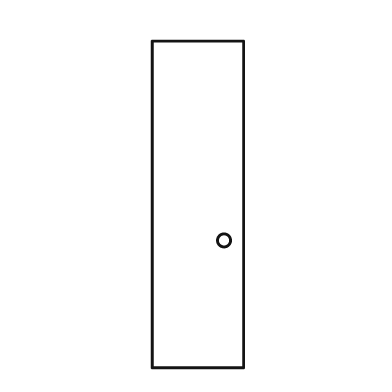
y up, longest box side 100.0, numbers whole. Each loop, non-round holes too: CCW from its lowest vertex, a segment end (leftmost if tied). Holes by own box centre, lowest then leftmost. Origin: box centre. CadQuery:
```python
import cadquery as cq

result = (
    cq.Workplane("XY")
    .moveTo(-14.0, -50.0)
    .lineTo(14.0, -50.0)
    .lineTo(14.0, 50.0)
    .lineTo(-14.0, 50.0)
    .close()
    .moveTo(8.0, -11.0)
    .circle(2.0)
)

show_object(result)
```